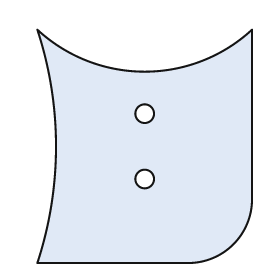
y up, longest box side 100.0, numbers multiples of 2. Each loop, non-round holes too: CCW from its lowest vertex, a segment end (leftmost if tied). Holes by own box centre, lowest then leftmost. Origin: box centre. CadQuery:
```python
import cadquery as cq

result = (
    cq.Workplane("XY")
    .moveTo(-46.0, -50.0)
    .lineTo(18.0, -50.0)
    .threePointArc((38.0, -42.0), (46.0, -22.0))
    .lineTo(46.0, 50.0)
    .threePointArc((0.0, 32.0), (-46.0, 50.0))
    .threePointArc((-38.0, 0.0), (-46.0, -50.0))
    .close()
    .moveTo(0.0, -14.0)
    .circle(4.0)
    .moveTo(0.0, 14.0)
    .circle(4.0)
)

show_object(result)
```